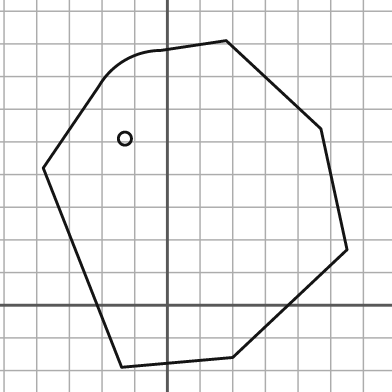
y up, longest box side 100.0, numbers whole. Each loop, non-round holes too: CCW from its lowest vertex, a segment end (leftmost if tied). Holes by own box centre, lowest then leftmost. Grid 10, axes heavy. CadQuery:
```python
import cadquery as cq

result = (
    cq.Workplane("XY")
    .moveTo(-14.0, -19.0)
    .lineTo(20.0, -16.0)
    .lineTo(55.0, 17.0)
    .lineTo(47.0, 54.0)
    .lineTo(18.0, 81.0)
    .lineTo(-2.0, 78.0)
    .threePointArc((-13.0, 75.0), (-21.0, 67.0))
    .lineTo(-38.0, 42.0)
    .close()
    .moveTo(-13.0, 51.0)
    .circle(2.0)
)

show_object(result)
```